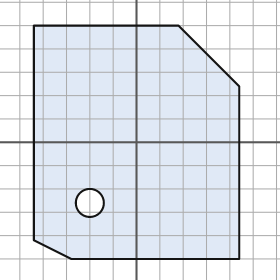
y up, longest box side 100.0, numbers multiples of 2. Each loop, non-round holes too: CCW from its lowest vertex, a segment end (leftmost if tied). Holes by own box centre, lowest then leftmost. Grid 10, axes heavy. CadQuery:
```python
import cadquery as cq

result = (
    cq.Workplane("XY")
    .moveTo(-28.0, -50.0)
    .lineTo(44.0, -50.0)
    .lineTo(44.0, 24.0)
    .lineTo(18.0, 50.0)
    .lineTo(-44.0, 50.0)
    .lineTo(-44.0, -42.0)
    .close()
    .moveTo(-20.0, -26.0)
    .circle(6.0)
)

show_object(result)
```